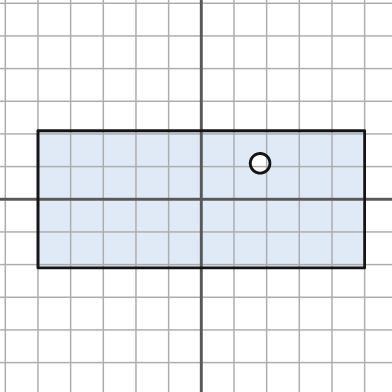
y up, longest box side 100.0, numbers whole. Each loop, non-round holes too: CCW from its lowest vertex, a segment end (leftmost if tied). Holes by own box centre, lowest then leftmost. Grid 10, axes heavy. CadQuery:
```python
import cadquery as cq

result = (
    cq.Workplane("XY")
    .moveTo(-50.0, -21.0)
    .lineTo(50.0, -21.0)
    .lineTo(50.0, 21.0)
    .lineTo(-50.0, 21.0)
    .close()
    .moveTo(18.0, 11.0)
    .circle(3.0)
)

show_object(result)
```